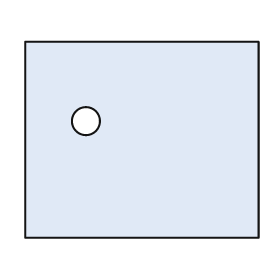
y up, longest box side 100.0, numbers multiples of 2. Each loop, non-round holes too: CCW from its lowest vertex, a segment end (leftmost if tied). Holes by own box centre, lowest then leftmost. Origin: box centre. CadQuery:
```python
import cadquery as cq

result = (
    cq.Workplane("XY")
    .moveTo(-50.0, -42.0)
    .lineTo(50.0, -42.0)
    .lineTo(50.0, 42.0)
    .lineTo(-50.0, 42.0)
    .close()
    .moveTo(-24.0, 8.0)
    .circle(6.0)
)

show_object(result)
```